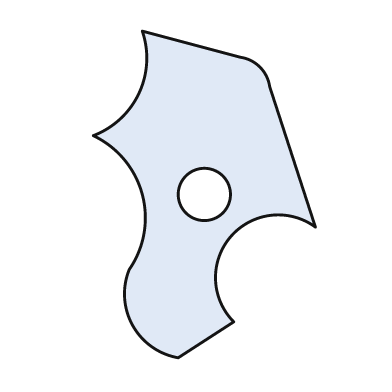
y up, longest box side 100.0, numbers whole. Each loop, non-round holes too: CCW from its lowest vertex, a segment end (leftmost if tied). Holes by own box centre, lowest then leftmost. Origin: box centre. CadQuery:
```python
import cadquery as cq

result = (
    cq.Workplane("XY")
    .moveTo(-8.0, -50.0)
    .lineTo(9.0, -39.0)
    .threePointArc((8.0, -13.0), (34.0, -10.0))
    .lineTo(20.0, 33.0)
    .threePointArc((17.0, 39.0), (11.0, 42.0))
    .lineTo(-19.0, 50.0)
    .threePointArc((-20.0, 31.0), (-34.0, 18.0))
    .threePointArc((-19.0, 0.0), (-23.0, -23.0))
    .threePointArc((-22.0, -40.0), (-8.0, -50.0))
    .close()
    .moveTo(0.0, 0.0)
    .circle(8.0)
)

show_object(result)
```